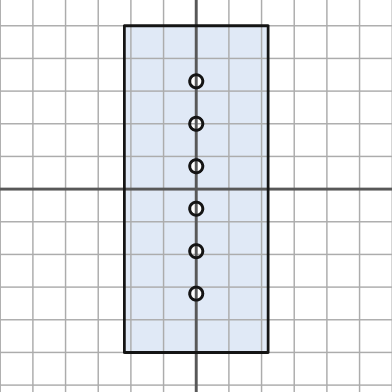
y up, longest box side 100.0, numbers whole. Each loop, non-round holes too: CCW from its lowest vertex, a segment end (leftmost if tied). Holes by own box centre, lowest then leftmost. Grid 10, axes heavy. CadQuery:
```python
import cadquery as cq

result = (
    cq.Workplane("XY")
    .moveTo(-22.0, -50.0)
    .lineTo(22.0, -50.0)
    .lineTo(22.0, 50.0)
    .lineTo(-22.0, 50.0)
    .close()
    .moveTo(0.0, -32.0)
    .circle(2.0)
    .moveTo(0.0, -19.0)
    .circle(2.0)
    .moveTo(0.0, -6.0)
    .circle(2.0)
    .moveTo(0.0, 7.0)
    .circle(2.0)
    .moveTo(0.0, 20.0)
    .circle(2.0)
    .moveTo(0.0, 33.0)
    .circle(2.0)
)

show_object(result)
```